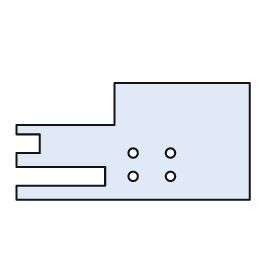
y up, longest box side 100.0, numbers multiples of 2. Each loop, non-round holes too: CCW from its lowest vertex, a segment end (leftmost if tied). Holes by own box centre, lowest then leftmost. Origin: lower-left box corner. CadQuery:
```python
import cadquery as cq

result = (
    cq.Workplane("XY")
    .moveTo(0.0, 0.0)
    .lineTo(100.0, 0.0)
    .lineTo(100.0, 50.0)
    .lineTo(42.0, 50.0)
    .lineTo(42.0, 32.0)
    .lineTo(0.0, 32.0)
    .lineTo(0.0, 28.0)
    .lineTo(10.0, 28.0)
    .lineTo(10.0, 20.0)
    .lineTo(0.0, 20.0)
    .lineTo(0.0, 14.0)
    .lineTo(38.0, 14.0)
    .lineTo(38.0, 6.0)
    .lineTo(0.0, 6.0)
    .close()
    .moveTo(50.0, 10.0)
    .circle(2.0)
    .moveTo(66.0, 10.0)
    .circle(2.0)
    .moveTo(50.0, 20.0)
    .circle(2.0)
    .moveTo(66.0, 20.0)
    .circle(2.0)
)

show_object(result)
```